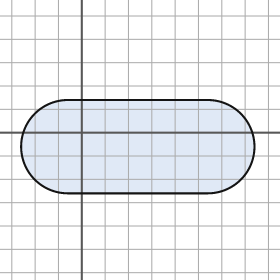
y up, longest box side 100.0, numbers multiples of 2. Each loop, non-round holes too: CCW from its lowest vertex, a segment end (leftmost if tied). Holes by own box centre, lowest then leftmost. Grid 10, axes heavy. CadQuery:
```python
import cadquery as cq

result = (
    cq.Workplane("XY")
    .moveTo(-6.0, -26.0)
    .lineTo(54.0, -26.0)
    .threePointArc((74.0, -6.0), (54.0, 14.0))
    .lineTo(-6.0, 14.0)
    .threePointArc((-26.0, -6.0), (-6.0, -26.0))
    .close()
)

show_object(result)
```